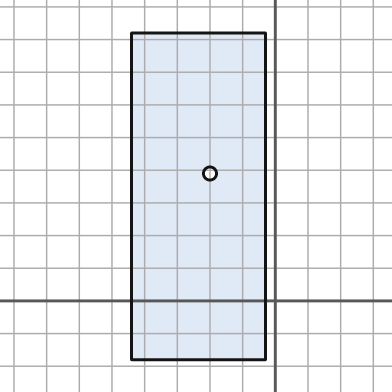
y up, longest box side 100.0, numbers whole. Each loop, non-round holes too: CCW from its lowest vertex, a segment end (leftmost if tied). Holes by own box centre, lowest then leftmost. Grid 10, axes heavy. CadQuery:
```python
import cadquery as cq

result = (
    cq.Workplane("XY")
    .moveTo(-44.0, -18.0)
    .lineTo(-3.0, -18.0)
    .lineTo(-3.0, 82.0)
    .lineTo(-44.0, 82.0)
    .close()
    .moveTo(-20.0, 39.0)
    .circle(2.0)
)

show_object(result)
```